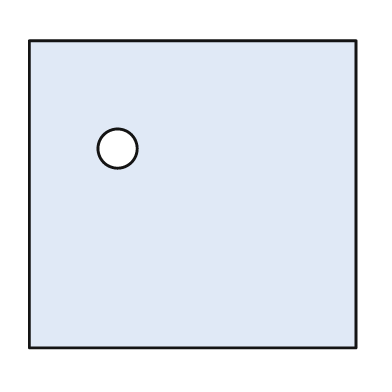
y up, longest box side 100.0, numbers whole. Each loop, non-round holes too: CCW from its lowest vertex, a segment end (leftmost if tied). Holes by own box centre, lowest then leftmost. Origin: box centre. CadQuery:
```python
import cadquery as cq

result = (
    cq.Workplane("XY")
    .moveTo(-50.0, -47.0)
    .lineTo(50.0, -47.0)
    .lineTo(50.0, 47.0)
    .lineTo(-50.0, 47.0)
    .close()
    .moveTo(-23.0, 14.0)
    .circle(6.0)
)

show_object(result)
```